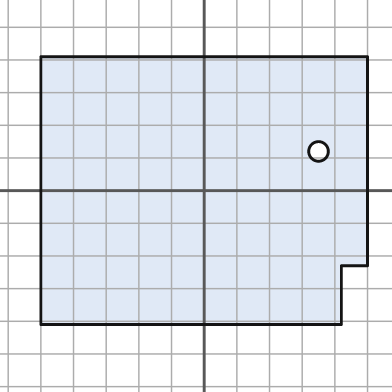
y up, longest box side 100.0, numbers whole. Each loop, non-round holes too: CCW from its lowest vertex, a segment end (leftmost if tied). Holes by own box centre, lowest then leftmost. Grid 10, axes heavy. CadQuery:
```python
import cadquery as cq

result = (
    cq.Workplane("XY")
    .moveTo(-50.0, -41.0)
    .lineTo(42.0, -41.0)
    .lineTo(42.0, -23.0)
    .lineTo(50.0, -23.0)
    .lineTo(50.0, 41.0)
    .lineTo(-50.0, 41.0)
    .close()
    .moveTo(35.0, 12.0)
    .circle(3.0)
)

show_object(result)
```